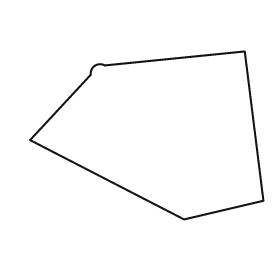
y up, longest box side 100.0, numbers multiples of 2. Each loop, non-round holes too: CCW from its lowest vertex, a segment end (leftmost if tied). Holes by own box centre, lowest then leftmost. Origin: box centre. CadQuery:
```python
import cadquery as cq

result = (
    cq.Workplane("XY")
    .moveTo(16.0, -36.0)
    .lineTo(50.0, -28.0)
    .lineTo(42.0, 36.0)
    .lineTo(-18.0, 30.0)
    .threePointArc((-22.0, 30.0), (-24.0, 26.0))
    .lineTo(-50.0, -2.0)
    .close()
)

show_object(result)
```